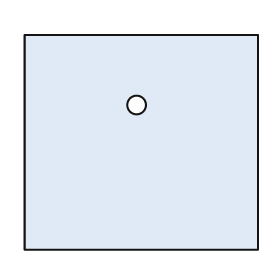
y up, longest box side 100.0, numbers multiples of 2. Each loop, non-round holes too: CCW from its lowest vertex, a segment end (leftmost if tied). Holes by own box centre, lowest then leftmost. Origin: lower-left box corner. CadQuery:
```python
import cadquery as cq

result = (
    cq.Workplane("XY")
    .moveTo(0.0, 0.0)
    .lineTo(100.0, 0.0)
    .lineTo(100.0, 92.0)
    .lineTo(0.0, 92.0)
    .close()
    .moveTo(48.0, 62.0)
    .circle(4.0)
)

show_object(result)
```